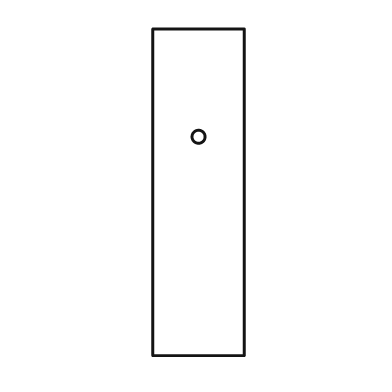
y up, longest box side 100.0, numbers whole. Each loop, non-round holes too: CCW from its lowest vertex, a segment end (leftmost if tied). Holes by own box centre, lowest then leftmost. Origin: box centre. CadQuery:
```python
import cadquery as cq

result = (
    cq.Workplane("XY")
    .moveTo(-14.0, -50.0)
    .lineTo(14.0, -50.0)
    .lineTo(14.0, 50.0)
    .lineTo(-14.0, 50.0)
    .close()
    .moveTo(0.0, 17.0)
    .circle(2.0)
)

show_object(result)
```